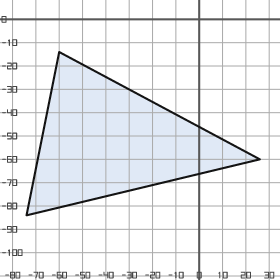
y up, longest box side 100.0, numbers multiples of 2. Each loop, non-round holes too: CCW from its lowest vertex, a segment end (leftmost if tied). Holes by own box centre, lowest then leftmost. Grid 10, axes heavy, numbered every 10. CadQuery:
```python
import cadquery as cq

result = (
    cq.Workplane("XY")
    .moveTo(-74.0, -84.0)
    .lineTo(26.0, -60.0)
    .lineTo(-60.0, -14.0)
    .close()
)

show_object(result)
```